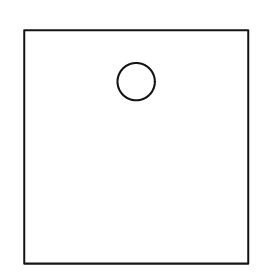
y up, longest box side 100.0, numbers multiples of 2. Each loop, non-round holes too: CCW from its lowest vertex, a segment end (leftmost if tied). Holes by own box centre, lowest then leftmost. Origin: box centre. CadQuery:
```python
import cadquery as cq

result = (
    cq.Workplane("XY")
    .moveTo(-48.0, -50.0)
    .lineTo(48.0, -50.0)
    .lineTo(48.0, 50.0)
    .lineTo(-48.0, 50.0)
    .close()
    .moveTo(0.0, 28.0)
    .circle(8.0)
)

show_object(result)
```